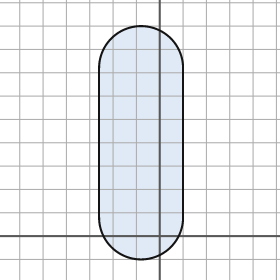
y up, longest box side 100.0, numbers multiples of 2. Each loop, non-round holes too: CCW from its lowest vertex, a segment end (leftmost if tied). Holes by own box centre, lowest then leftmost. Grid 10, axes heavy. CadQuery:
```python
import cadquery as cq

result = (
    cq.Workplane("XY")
    .moveTo(-26.0, 8.0)
    .threePointArc((-8.0, -10.0), (10.0, 8.0))
    .lineTo(10.0, 72.0)
    .threePointArc((-8.0, 90.0), (-26.0, 72.0))
    .close()
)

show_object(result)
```